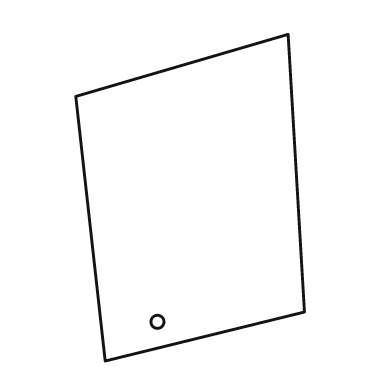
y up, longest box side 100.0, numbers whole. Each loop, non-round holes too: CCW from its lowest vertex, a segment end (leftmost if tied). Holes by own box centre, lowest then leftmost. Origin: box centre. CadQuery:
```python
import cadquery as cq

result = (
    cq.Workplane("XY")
    .moveTo(-26.0, -50.0)
    .lineTo(35.0, -35.0)
    .lineTo(30.0, 50.0)
    .lineTo(-35.0, 31.0)
    .close()
    .moveTo(-10.0, -38.0)
    .circle(2.0)
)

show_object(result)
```